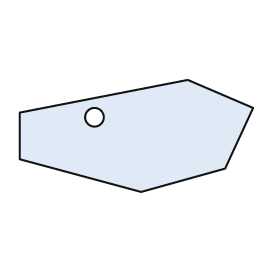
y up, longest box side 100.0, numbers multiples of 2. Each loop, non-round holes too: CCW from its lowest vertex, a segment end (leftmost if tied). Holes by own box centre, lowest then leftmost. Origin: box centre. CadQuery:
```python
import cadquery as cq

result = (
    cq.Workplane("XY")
    .moveTo(2.0, -24.0)
    .lineTo(38.0, -14.0)
    .lineTo(50.0, 12.0)
    .lineTo(22.0, 24.0)
    .lineTo(-50.0, 10.0)
    .lineTo(-50.0, -10.0)
    .close()
    .moveTo(-18.0, 8.0)
    .circle(4.0)
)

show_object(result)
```